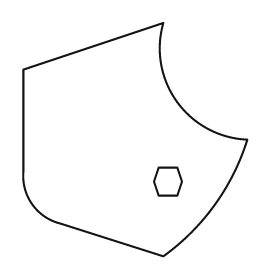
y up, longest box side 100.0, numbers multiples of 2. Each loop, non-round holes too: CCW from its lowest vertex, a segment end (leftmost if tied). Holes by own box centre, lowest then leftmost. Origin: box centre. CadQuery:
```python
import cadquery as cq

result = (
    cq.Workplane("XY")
    .moveTo(12.0, -50.0)
    .threePointArc((34.0, -28.0), (48.0, 0.0))
    .threePointArc((18.0, 16.0), (12.0, 50.0))
    .lineTo(-48.0, 30.0)
    .lineTo(-48.0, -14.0)
    .threePointArc((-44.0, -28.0), (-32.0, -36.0))
    .close()
    .moveTo(10.0, -24.0)
    .lineTo(18.0, -24.0)
    .lineTo(20.0, -18.0)
    .lineTo(18.0, -12.0)
    .lineTo(10.0, -12.0)
    .lineTo(8.0, -18.0)
    .close()
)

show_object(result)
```